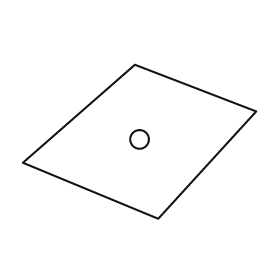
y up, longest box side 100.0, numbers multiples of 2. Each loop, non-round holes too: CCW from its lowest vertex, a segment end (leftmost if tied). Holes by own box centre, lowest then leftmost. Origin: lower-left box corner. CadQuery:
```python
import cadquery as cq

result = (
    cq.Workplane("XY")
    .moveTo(58.0, 0.0)
    .lineTo(100.0, 46.0)
    .lineTo(48.0, 66.0)
    .lineTo(0.0, 24.0)
    .close()
    .moveTo(50.0, 34.0)
    .circle(4.0)
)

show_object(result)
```